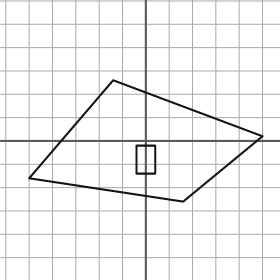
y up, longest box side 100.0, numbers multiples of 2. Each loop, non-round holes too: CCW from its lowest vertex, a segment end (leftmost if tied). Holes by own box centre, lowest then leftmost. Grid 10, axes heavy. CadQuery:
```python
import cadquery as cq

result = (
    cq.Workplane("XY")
    .moveTo(16.0, -26.0)
    .lineTo(50.0, 2.0)
    .lineTo(-14.0, 26.0)
    .lineTo(-50.0, -16.0)
    .close()
    .moveTo(-4.0, -14.0)
    .lineTo(4.0, -14.0)
    .lineTo(4.0, -2.0)
    .lineTo(-4.0, -2.0)
    .close()
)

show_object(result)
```